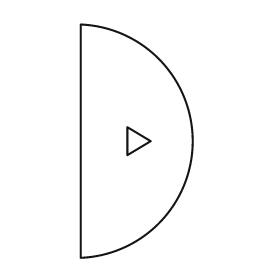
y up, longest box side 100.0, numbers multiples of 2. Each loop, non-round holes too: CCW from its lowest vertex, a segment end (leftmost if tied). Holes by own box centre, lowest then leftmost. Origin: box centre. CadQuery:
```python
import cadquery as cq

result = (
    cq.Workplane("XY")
    .moveTo(-24.0, -50.0)
    .threePointArc((24.0, 0.0), (-24.0, 50.0))
    .close()
    .moveTo(-4.0, -6.0)
    .lineTo(6.0, 0.0)
    .lineTo(-4.0, 6.0)
    .close()
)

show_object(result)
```